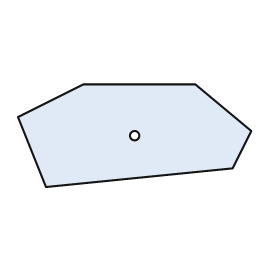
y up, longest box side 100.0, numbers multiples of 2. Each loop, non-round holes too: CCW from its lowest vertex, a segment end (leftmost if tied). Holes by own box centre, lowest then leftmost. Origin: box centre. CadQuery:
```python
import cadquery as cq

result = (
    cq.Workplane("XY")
    .moveTo(-38.0, -22.0)
    .lineTo(42.0, -14.0)
    .lineTo(50.0, 2.0)
    .lineTo(26.0, 22.0)
    .lineTo(-22.0, 22.0)
    .lineTo(-50.0, 8.0)
    .close()
    .moveTo(0.0, 0.0)
    .circle(2.0)
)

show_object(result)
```